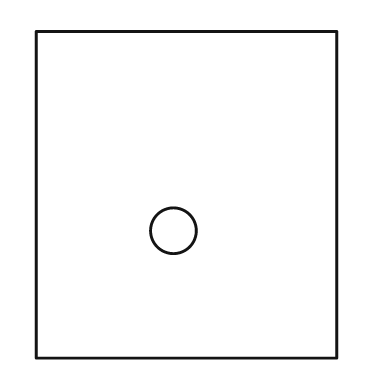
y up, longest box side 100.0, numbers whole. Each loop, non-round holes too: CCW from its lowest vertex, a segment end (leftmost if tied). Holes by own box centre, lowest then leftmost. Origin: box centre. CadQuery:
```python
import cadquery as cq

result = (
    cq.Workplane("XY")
    .moveTo(-46.0, -50.0)
    .lineTo(46.0, -50.0)
    .lineTo(46.0, 50.0)
    .lineTo(-46.0, 50.0)
    .close()
    .moveTo(-4.0, -11.0)
    .circle(7.0)
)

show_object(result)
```